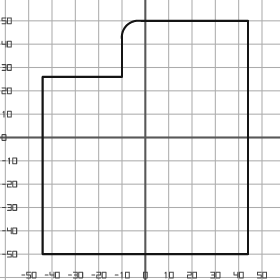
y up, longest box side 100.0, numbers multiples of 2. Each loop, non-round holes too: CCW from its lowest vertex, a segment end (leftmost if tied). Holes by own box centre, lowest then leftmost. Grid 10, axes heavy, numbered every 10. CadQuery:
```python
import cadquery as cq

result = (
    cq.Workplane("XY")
    .moveTo(-44.0, -50.0)
    .lineTo(44.0, -50.0)
    .lineTo(44.0, 50.0)
    .lineTo(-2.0, 50.0)
    .threePointArc((-8.0, 48.0), (-10.0, 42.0))
    .lineTo(-10.0, 26.0)
    .lineTo(-44.0, 26.0)
    .close()
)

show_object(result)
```